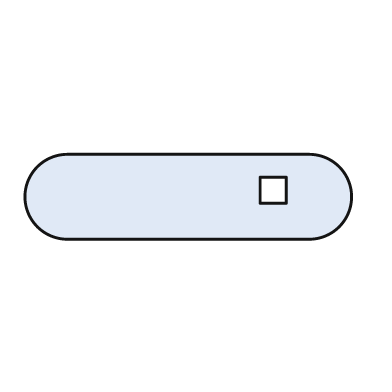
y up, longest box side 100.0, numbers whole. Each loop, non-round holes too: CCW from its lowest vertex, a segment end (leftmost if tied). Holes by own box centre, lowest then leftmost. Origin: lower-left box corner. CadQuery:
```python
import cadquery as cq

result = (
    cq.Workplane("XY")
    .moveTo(13.0, 0.0)
    .lineTo(87.0, 0.0)
    .threePointArc((100.0, 13.0), (87.0, 26.0))
    .lineTo(13.0, 26.0)
    .threePointArc((0.0, 13.0), (13.0, 0.0))
    .close()
    .moveTo(72.0, 11.0)
    .lineTo(80.0, 11.0)
    .lineTo(80.0, 19.0)
    .lineTo(72.0, 19.0)
    .close()
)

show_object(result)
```